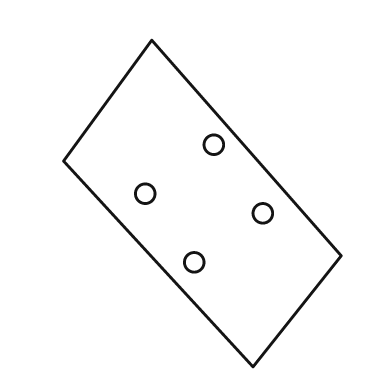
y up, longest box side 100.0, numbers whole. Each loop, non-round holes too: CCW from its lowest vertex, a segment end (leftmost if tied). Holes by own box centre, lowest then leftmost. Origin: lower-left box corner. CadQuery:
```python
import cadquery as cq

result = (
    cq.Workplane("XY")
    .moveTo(58.0, 0.0)
    .lineTo(85.0, 34.0)
    .lineTo(27.0, 100.0)
    .lineTo(0.0, 63.0)
    .close()
    .moveTo(40.0, 32.0)
    .circle(3.0)
    .moveTo(61.0, 47.0)
    .circle(3.0)
    .moveTo(25.0, 53.0)
    .circle(3.0)
    .moveTo(46.0, 68.0)
    .circle(3.0)
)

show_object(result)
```